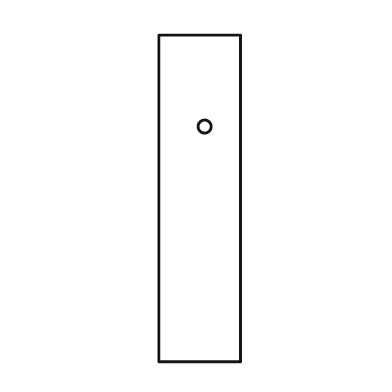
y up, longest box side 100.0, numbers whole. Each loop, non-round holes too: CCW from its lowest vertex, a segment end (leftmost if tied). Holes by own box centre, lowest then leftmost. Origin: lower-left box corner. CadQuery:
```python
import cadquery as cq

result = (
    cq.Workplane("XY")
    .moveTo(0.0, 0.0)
    .lineTo(25.0, 0.0)
    .lineTo(25.0, 100.0)
    .lineTo(0.0, 100.0)
    .close()
    .moveTo(14.0, 72.0)
    .circle(2.0)
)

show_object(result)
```